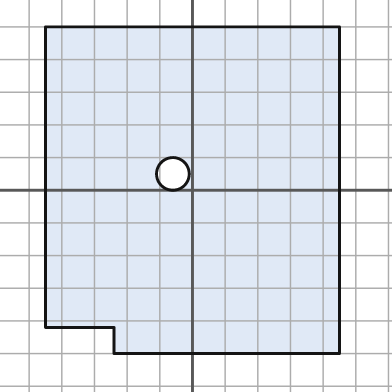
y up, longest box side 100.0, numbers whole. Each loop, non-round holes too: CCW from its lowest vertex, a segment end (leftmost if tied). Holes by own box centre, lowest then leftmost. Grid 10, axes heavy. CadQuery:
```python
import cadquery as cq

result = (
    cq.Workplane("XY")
    .moveTo(-24.0, -50.0)
    .lineTo(45.0, -50.0)
    .lineTo(45.0, 50.0)
    .lineTo(-45.0, 50.0)
    .lineTo(-45.0, -42.0)
    .lineTo(-24.0, -42.0)
    .close()
    .moveTo(-6.0, 5.0)
    .circle(5.0)
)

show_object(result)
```